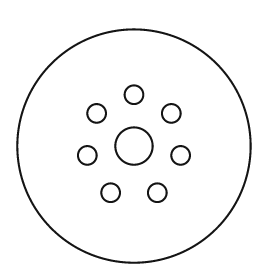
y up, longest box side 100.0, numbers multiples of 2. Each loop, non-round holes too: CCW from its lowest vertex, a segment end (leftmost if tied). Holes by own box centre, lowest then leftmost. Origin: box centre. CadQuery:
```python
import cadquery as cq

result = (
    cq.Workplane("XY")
    .moveTo(0.0, 0.0)
    .circle(50.0)
    .moveTo(-10.0, -20.0)
    .circle(4.0)
    .moveTo(10.0, -20.0)
    .circle(4.0)
    .moveTo(-20.0, -4.0)
    .circle(4.0)
    .moveTo(20.0, -4.0)
    .circle(4.0)
    .moveTo(0.0, 0.0)
    .circle(8.0)
    .moveTo(-16.0, 14.0)
    .circle(4.0)
    .moveTo(16.0, 14.0)
    .circle(4.0)
    .moveTo(0.0, 22.0)
    .circle(4.0)
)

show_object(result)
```